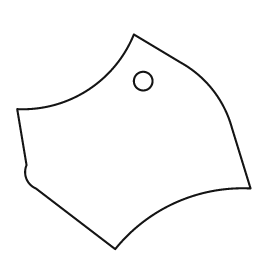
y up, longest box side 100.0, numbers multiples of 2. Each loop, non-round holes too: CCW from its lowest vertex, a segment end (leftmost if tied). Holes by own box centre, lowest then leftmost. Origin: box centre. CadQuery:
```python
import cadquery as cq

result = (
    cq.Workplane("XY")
    .moveTo(-8.0, -46.0)
    .threePointArc((18.0, -26.0), (50.0, -20.0))
    .lineTo(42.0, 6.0)
    .threePointArc((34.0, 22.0), (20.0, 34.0))
    .lineTo(0.0, 46.0)
    .threePointArc((-20.0, 22.0), (-50.0, 14.0))
    .lineTo(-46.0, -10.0)
    .threePointArc((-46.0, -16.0), (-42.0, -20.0))
    .close()
    .moveTo(4.0, 26.0)
    .circle(4.0)
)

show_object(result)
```